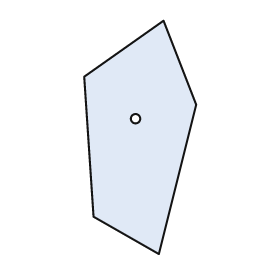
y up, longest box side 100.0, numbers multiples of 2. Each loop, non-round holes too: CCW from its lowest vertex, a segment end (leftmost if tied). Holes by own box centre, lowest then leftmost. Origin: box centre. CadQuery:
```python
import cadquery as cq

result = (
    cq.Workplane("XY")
    .moveTo(8.0, -50.0)
    .lineTo(24.0, 14.0)
    .lineTo(10.0, 50.0)
    .lineTo(-24.0, 26.0)
    .lineTo(-20.0, -34.0)
    .close()
    .moveTo(-2.0, 8.0)
    .circle(2.0)
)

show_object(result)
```